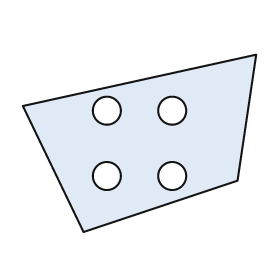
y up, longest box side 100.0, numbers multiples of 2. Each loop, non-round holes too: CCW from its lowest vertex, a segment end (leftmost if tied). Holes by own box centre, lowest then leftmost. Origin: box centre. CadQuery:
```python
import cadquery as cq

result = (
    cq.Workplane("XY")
    .moveTo(-24.0, -38.0)
    .lineTo(42.0, -16.0)
    .lineTo(50.0, 38.0)
    .lineTo(-50.0, 16.0)
    .close()
    .moveTo(-14.0, -14.0)
    .circle(6.0)
    .moveTo(14.0, -14.0)
    .circle(6.0)
    .moveTo(-14.0, 14.0)
    .circle(6.0)
    .moveTo(14.0, 14.0)
    .circle(6.0)
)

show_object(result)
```